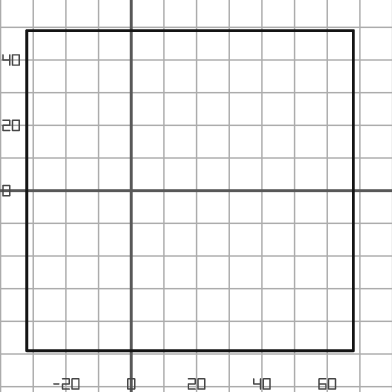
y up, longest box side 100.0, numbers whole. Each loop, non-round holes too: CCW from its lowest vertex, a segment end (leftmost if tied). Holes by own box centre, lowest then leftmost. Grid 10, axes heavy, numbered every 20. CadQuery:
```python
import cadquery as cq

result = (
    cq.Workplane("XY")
    .moveTo(-32.0, -49.0)
    .lineTo(68.0, -49.0)
    .lineTo(68.0, 49.0)
    .lineTo(-32.0, 49.0)
    .close()
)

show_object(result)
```